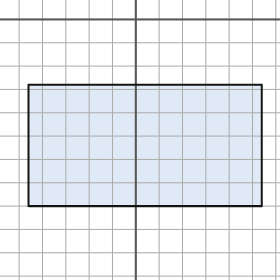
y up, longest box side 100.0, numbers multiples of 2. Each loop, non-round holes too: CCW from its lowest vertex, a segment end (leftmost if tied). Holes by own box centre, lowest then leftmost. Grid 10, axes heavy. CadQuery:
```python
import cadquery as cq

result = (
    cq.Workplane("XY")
    .moveTo(-46.0, -80.0)
    .lineTo(54.0, -80.0)
    .lineTo(54.0, -28.0)
    .lineTo(-46.0, -28.0)
    .close()
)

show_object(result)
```